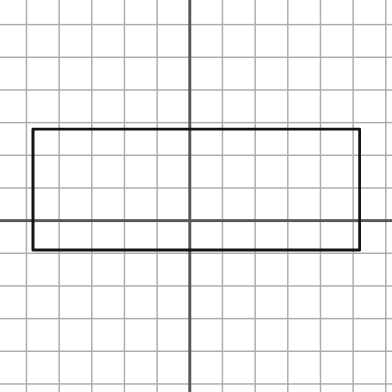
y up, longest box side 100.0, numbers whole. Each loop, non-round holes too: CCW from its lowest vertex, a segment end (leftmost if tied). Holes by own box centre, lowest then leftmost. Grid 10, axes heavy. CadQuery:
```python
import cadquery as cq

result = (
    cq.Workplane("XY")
    .moveTo(-48.0, -9.0)
    .lineTo(52.0, -9.0)
    .lineTo(52.0, 28.0)
    .lineTo(-48.0, 28.0)
    .close()
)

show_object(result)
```